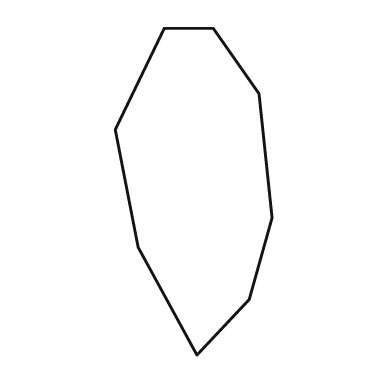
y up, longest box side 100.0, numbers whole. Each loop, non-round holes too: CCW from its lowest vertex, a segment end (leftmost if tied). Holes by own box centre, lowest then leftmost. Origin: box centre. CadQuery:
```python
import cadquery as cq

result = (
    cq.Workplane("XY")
    .moveTo(1.0, -50.0)
    .lineTo(17.0, -33.0)
    .lineTo(24.0, -8.0)
    .lineTo(20.0, 30.0)
    .lineTo(6.0, 50.0)
    .lineTo(-9.0, 50.0)
    .lineTo(-24.0, 19.0)
    .lineTo(-17.0, -17.0)
    .close()
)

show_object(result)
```